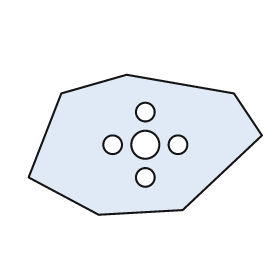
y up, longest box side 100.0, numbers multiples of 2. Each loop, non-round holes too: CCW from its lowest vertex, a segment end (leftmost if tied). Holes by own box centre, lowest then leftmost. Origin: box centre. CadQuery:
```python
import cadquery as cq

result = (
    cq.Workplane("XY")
    .moveTo(-20.0, -30.0)
    .lineTo(16.0, -28.0)
    .lineTo(50.0, 4.0)
    .lineTo(38.0, 22.0)
    .lineTo(-8.0, 30.0)
    .lineTo(-36.0, 22.0)
    .lineTo(-50.0, -14.0)
    .close()
    .moveTo(0.0, -14.0)
    .circle(4.0)
    .moveTo(-14.0, 0.0)
    .circle(4.0)
    .moveTo(0.0, 0.0)
    .circle(6.0)
    .moveTo(14.0, 0.0)
    .circle(4.0)
    .moveTo(0.0, 14.0)
    .circle(4.0)
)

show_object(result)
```